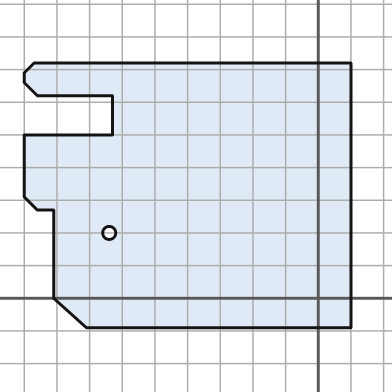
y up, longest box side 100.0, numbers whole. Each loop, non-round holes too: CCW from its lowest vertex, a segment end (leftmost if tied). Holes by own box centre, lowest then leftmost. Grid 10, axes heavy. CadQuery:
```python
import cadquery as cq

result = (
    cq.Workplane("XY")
    .moveTo(-71.0, -9.0)
    .lineTo(10.0, -9.0)
    .lineTo(10.0, 72.0)
    .lineTo(-87.0, 72.0)
    .lineTo(-90.0, 69.0)
    .lineTo(-90.0, 66.0)
    .lineTo(-86.0, 62.0)
    .lineTo(-63.0, 62.0)
    .lineTo(-63.0, 50.0)
    .lineTo(-90.0, 50.0)
    .lineTo(-90.0, 31.0)
    .lineTo(-86.0, 27.0)
    .lineTo(-81.0, 27.0)
    .lineTo(-81.0, 0.0)
    .close()
    .moveTo(-64.0, 20.0)
    .circle(2.0)
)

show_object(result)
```